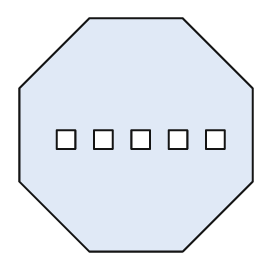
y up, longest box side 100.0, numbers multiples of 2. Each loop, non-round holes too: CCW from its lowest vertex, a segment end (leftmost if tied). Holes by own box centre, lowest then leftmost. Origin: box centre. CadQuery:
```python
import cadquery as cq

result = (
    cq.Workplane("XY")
    .moveTo(-20.0, -50.0)
    .lineTo(20.0, -50.0)
    .lineTo(50.0, -20.0)
    .lineTo(50.0, 20.0)
    .lineTo(20.0, 50.0)
    .lineTo(-20.0, 50.0)
    .lineTo(-50.0, 20.0)
    .lineTo(-50.0, -20.0)
    .close()
    .moveTo(-34.0, -6.0)
    .lineTo(-26.0, -6.0)
    .lineTo(-26.0, 2.0)
    .lineTo(-34.0, 2.0)
    .close()
    .moveTo(-18.0, -6.0)
    .lineTo(-10.0, -6.0)
    .lineTo(-10.0, 2.0)
    .lineTo(-18.0, 2.0)
    .close()
    .moveTo(-2.0, -6.0)
    .lineTo(6.0, -6.0)
    .lineTo(6.0, 2.0)
    .lineTo(-2.0, 2.0)
    .close()
    .moveTo(14.0, -6.0)
    .lineTo(22.0, -6.0)
    .lineTo(22.0, 2.0)
    .lineTo(14.0, 2.0)
    .close()
    .moveTo(30.0, -6.0)
    .lineTo(38.0, -6.0)
    .lineTo(38.0, 2.0)
    .lineTo(30.0, 2.0)
    .close()
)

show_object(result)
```